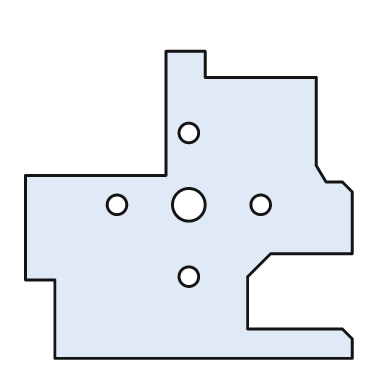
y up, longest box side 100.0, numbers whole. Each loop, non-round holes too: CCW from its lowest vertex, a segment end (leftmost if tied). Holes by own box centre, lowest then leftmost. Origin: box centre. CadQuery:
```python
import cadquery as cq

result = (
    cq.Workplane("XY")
    .moveTo(-41.0, -47.0)
    .lineTo(50.0, -47.0)
    .lineTo(50.0, -41.0)
    .lineTo(47.0, -38.0)
    .lineTo(18.0, -38.0)
    .lineTo(18.0, -22.0)
    .lineTo(25.0, -15.0)
    .lineTo(50.0, -15.0)
    .lineTo(50.0, 4.0)
    .lineTo(47.0, 7.0)
    .lineTo(42.0, 7.0)
    .lineTo(39.0, 12.0)
    .lineTo(39.0, 39.0)
    .lineTo(5.0, 39.0)
    .lineTo(5.0, 47.0)
    .lineTo(-7.0, 47.0)
    .lineTo(-7.0, 9.0)
    .lineTo(-50.0, 9.0)
    .lineTo(-50.0, -23.0)
    .lineTo(-41.0, -23.0)
    .close()
    .moveTo(0.0, -22.0)
    .circle(3.0)
    .moveTo(-22.0, 0.0)
    .circle(3.0)
    .moveTo(0.0, 0.0)
    .circle(5.0)
    .moveTo(22.0, 0.0)
    .circle(3.0)
    .moveTo(0.0, 22.0)
    .circle(3.0)
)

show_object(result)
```